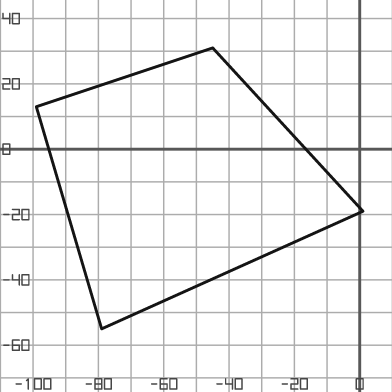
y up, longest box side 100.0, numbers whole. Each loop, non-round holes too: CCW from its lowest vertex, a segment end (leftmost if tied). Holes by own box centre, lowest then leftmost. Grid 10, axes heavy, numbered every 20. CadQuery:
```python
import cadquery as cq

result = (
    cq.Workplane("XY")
    .moveTo(-79.0, -55.0)
    .lineTo(1.0, -19.0)
    .lineTo(-45.0, 31.0)
    .lineTo(-99.0, 13.0)
    .close()
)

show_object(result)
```